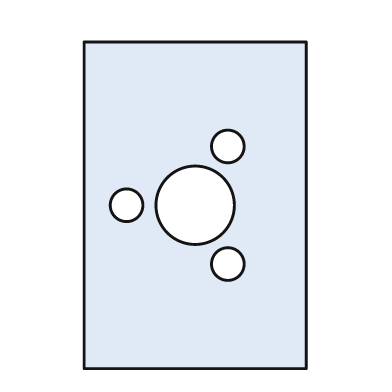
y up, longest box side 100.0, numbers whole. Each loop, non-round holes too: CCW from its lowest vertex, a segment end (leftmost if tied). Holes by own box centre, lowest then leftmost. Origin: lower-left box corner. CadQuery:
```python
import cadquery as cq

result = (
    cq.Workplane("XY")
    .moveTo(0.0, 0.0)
    .lineTo(68.0, 0.0)
    .lineTo(68.0, 100.0)
    .lineTo(0.0, 100.0)
    .close()
    .moveTo(44.0, 32.0)
    .circle(5.0)
    .moveTo(13.0, 50.0)
    .circle(5.0)
    .moveTo(34.0, 50.0)
    .circle(12.0)
    .moveTo(44.0, 68.0)
    .circle(5.0)
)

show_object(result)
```